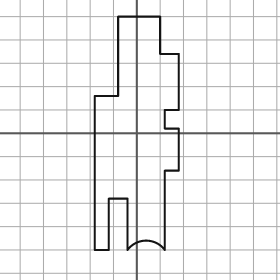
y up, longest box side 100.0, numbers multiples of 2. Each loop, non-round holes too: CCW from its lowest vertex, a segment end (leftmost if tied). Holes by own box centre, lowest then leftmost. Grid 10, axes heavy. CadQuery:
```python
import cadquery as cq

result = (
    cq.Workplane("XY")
    .moveTo(-18.0, -50.0)
    .lineTo(-12.0, -50.0)
    .lineTo(-12.0, -28.0)
    .lineTo(-4.0, -28.0)
    .lineTo(-4.0, -50.0)
    .threePointArc((4.0, -46.0), (12.0, -50.0))
    .lineTo(12.0, -16.0)
    .lineTo(18.0, -16.0)
    .lineTo(18.0, 2.0)
    .lineTo(12.0, 2.0)
    .lineTo(12.0, 10.0)
    .lineTo(18.0, 10.0)
    .lineTo(18.0, 34.0)
    .lineTo(10.0, 34.0)
    .lineTo(10.0, 50.0)
    .lineTo(-8.0, 50.0)
    .lineTo(-8.0, 16.0)
    .lineTo(-18.0, 16.0)
    .close()
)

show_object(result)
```